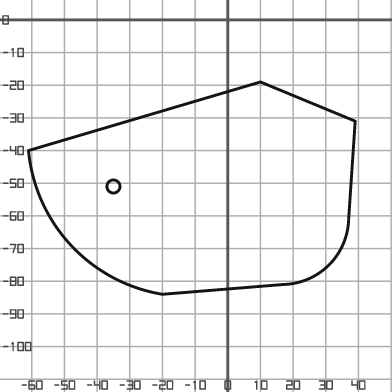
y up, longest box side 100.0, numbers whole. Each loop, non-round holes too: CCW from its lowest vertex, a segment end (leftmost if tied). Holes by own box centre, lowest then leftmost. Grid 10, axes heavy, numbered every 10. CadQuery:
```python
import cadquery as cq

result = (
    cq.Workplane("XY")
    .moveTo(-20.0, -84.0)
    .lineTo(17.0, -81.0)
    .threePointArc((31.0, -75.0), (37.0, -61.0))
    .lineTo(39.0, -31.0)
    .lineTo(10.0, -19.0)
    .lineTo(-61.0, -40.0)
    .threePointArc((-48.0, -69.0), (-20.0, -84.0))
    .close()
    .moveTo(-35.0, -51.0)
    .circle(2.0)
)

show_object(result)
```